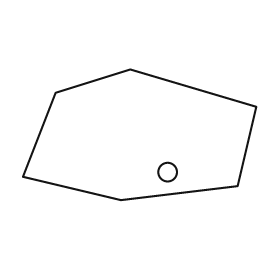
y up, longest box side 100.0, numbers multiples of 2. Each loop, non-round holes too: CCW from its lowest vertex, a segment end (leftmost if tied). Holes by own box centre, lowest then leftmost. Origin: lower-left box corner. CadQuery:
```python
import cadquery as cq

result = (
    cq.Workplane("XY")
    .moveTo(42.0, 0.0)
    .lineTo(92.0, 6.0)
    .lineTo(100.0, 40.0)
    .lineTo(46.0, 56.0)
    .lineTo(14.0, 46.0)
    .lineTo(0.0, 10.0)
    .close()
    .moveTo(62.0, 12.0)
    .circle(4.0)
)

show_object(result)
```